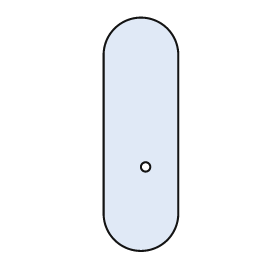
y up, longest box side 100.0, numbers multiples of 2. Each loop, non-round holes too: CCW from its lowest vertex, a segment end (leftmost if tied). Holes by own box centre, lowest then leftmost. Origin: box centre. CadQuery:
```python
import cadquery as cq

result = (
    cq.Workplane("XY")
    .moveTo(-16.0, -34.0)
    .threePointArc((0.0, -50.0), (16.0, -34.0))
    .lineTo(16.0, 34.0)
    .threePointArc((0.0, 50.0), (-16.0, 34.0))
    .close()
    .moveTo(2.0, -14.0)
    .circle(2.0)
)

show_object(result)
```